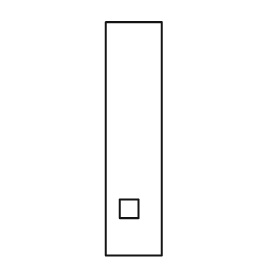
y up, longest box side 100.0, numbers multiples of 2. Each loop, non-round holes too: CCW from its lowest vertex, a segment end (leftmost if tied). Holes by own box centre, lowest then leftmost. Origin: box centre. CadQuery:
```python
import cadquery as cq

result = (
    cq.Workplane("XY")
    .moveTo(-12.0, -50.0)
    .lineTo(12.0, -50.0)
    .lineTo(12.0, 50.0)
    .lineTo(-12.0, 50.0)
    .close()
    .moveTo(-6.0, -34.0)
    .lineTo(2.0, -34.0)
    .lineTo(2.0, -26.0)
    .lineTo(-6.0, -26.0)
    .close()
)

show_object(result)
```